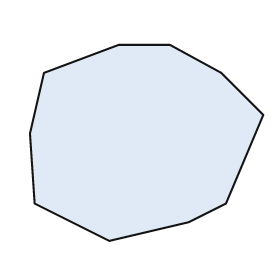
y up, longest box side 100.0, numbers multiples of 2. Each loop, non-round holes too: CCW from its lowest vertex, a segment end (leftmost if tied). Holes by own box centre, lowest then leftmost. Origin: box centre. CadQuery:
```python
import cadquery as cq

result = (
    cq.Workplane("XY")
    .moveTo(-16.0, -42.0)
    .lineTo(18.0, -34.0)
    .lineTo(34.0, -26.0)
    .lineTo(50.0, 12.0)
    .lineTo(32.0, 30.0)
    .lineTo(10.0, 42.0)
    .lineTo(-12.0, 42.0)
    .lineTo(-44.0, 30.0)
    .lineTo(-50.0, 4.0)
    .lineTo(-48.0, -26.0)
    .close()
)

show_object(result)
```